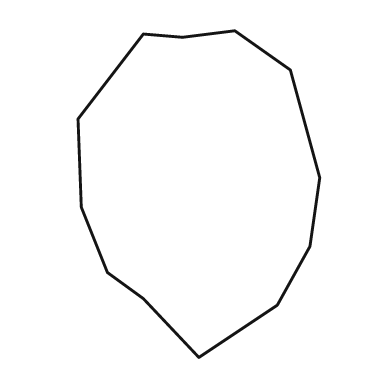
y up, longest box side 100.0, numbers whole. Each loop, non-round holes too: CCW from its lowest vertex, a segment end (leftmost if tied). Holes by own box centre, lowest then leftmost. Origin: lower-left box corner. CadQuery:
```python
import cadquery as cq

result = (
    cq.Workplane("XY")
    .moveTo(37.0, 0.0)
    .lineTo(61.0, 16.0)
    .lineTo(71.0, 34.0)
    .lineTo(74.0, 55.0)
    .lineTo(65.0, 88.0)
    .lineTo(48.0, 100.0)
    .lineTo(32.0, 98.0)
    .lineTo(20.0, 99.0)
    .lineTo(0.0, 73.0)
    .lineTo(1.0, 46.0)
    .lineTo(9.0, 26.0)
    .lineTo(20.0, 18.0)
    .close()
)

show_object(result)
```